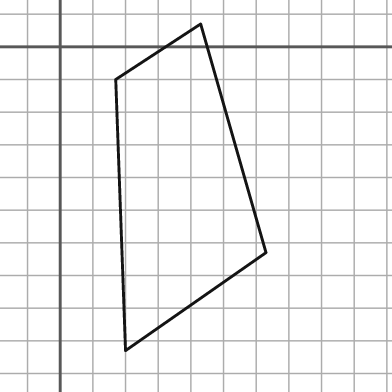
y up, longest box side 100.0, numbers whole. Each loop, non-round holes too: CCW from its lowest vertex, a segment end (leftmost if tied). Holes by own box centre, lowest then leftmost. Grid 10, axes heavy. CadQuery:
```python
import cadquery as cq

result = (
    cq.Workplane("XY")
    .moveTo(20.0, -93.0)
    .lineTo(63.0, -63.0)
    .lineTo(43.0, 7.0)
    .lineTo(17.0, -10.0)
    .close()
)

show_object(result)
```